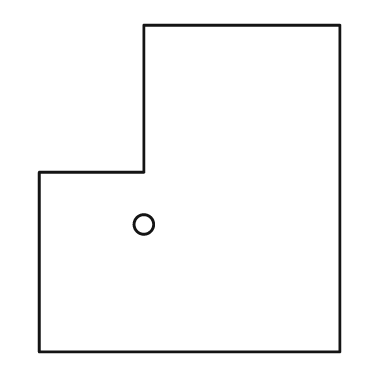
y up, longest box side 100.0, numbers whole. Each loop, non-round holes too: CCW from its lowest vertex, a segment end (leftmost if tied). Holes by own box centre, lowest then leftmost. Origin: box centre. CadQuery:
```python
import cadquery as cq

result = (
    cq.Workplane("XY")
    .moveTo(-46.0, -50.0)
    .lineTo(46.0, -50.0)
    .lineTo(46.0, 50.0)
    .lineTo(-14.0, 50.0)
    .lineTo(-14.0, 5.0)
    .lineTo(-46.0, 5.0)
    .close()
    .moveTo(-14.0, -11.0)
    .circle(3.0)
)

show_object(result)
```